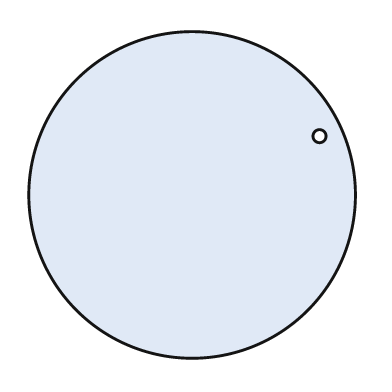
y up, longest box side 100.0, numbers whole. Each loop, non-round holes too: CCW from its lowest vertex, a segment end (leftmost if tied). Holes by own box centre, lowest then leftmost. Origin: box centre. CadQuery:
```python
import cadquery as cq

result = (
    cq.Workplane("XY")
    .moveTo(0.0, 0.0)
    .circle(50.0)
    .moveTo(39.0, 18.0)
    .circle(2.0)
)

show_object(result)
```